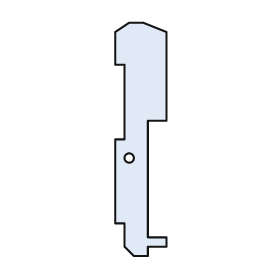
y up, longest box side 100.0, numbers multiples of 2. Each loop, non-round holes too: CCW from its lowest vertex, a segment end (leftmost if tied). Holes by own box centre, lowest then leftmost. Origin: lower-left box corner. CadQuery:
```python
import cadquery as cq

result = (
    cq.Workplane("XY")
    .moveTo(8.0, 0.0)
    .lineTo(14.0, 0.0)
    .lineTo(14.0, 4.0)
    .lineTo(22.0, 4.0)
    .lineTo(22.0, 8.0)
    .lineTo(14.0, 8.0)
    .lineTo(14.0, 58.0)
    .lineTo(22.0, 58.0)
    .lineTo(22.0, 96.0)
    .lineTo(12.0, 100.0)
    .lineTo(6.0, 100.0)
    .lineTo(0.0, 96.0)
    .lineTo(0.0, 82.0)
    .lineTo(4.0, 82.0)
    .lineTo(4.0, 50.0)
    .lineTo(0.0, 50.0)
    .lineTo(0.0, 14.0)
    .lineTo(4.0, 14.0)
    .lineTo(4.0, 4.0)
    .close()
    .moveTo(6.0, 42.0)
    .circle(2.0)
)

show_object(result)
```